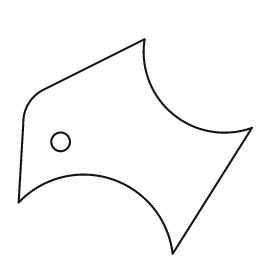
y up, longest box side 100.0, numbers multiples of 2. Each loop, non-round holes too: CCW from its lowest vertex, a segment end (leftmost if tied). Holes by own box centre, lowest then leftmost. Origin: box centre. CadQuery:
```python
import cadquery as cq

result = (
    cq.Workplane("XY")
    .moveTo(16.0, -46.0)
    .lineTo(50.0, 8.0)
    .threePointArc((16.0, 14.0), (4.0, 46.0))
    .lineTo(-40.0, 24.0)
    .threePointArc((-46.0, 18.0), (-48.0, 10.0))
    .lineTo(-50.0, -24.0)
    .threePointArc((-10.0, -14.0), (16.0, -46.0))
    .close()
    .moveTo(-32.0, 2.0)
    .circle(4.0)
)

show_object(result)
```